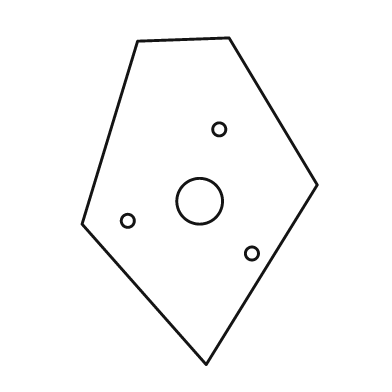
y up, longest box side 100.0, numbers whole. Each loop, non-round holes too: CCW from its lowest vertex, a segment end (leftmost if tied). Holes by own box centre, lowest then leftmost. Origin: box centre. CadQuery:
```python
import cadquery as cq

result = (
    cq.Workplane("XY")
    .moveTo(2.0, -50.0)
    .lineTo(36.0, 5.0)
    .lineTo(9.0, 50.0)
    .lineTo(-19.0, 49.0)
    .lineTo(-36.0, -7.0)
    .close()
    .moveTo(16.0, -16.0)
    .circle(2.0)
    .moveTo(-22.0, -6.0)
    .circle(2.0)
    .moveTo(0.0, 0.0)
    .circle(7.0)
    .moveTo(6.0, 22.0)
    .circle(2.0)
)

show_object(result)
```